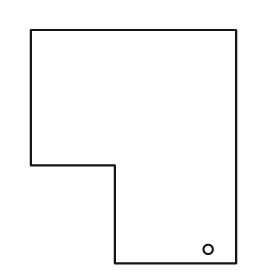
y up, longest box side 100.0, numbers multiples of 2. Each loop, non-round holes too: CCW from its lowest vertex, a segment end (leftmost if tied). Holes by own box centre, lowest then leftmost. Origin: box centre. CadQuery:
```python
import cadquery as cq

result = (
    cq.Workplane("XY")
    .moveTo(-8.0, -50.0)
    .lineTo(44.0, -50.0)
    .lineTo(44.0, 50.0)
    .lineTo(-44.0, 50.0)
    .lineTo(-44.0, -8.0)
    .lineTo(-8.0, -8.0)
    .close()
    .moveTo(32.0, -44.0)
    .circle(2.0)
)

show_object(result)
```